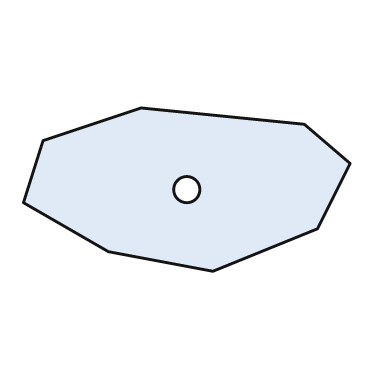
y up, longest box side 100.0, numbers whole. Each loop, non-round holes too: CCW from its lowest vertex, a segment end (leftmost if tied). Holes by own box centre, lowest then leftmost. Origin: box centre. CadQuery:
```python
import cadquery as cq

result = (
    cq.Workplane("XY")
    .moveTo(8.0, -25.0)
    .lineTo(40.0, -12.0)
    .lineTo(50.0, 8.0)
    .lineTo(36.0, 20.0)
    .lineTo(-14.0, 25.0)
    .lineTo(-44.0, 15.0)
    .lineTo(-50.0, -4.0)
    .lineTo(-24.0, -19.0)
    .close()
    .moveTo(0.0, 0.0)
    .circle(4.0)
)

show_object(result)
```